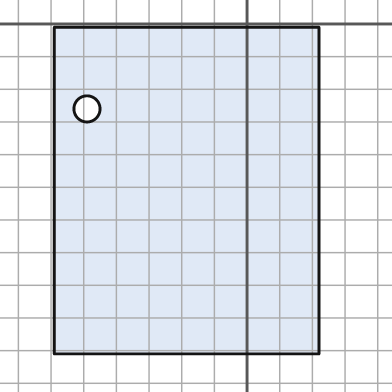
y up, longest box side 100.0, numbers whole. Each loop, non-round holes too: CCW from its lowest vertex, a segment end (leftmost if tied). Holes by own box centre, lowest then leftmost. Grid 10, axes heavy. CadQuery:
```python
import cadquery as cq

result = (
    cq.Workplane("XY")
    .moveTo(-59.0, -101.0)
    .lineTo(22.0, -101.0)
    .lineTo(22.0, -1.0)
    .lineTo(-59.0, -1.0)
    .close()
    .moveTo(-49.0, -26.0)
    .circle(4.0)
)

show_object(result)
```